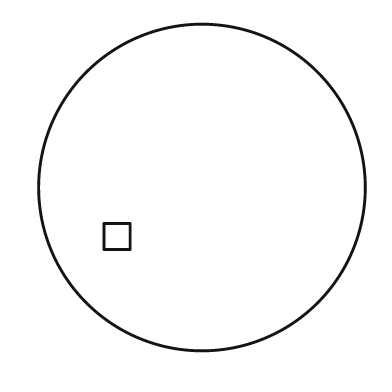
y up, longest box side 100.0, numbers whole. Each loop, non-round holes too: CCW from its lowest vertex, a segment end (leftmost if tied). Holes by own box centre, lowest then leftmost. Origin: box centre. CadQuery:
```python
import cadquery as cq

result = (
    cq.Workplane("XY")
    .moveTo(0.0, 0.0)
    .circle(50.0)
    .moveTo(-30.0, -19.0)
    .lineTo(-22.0, -19.0)
    .lineTo(-22.0, -11.0)
    .lineTo(-30.0, -11.0)
    .close()
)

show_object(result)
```